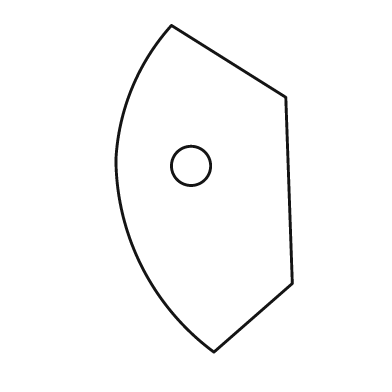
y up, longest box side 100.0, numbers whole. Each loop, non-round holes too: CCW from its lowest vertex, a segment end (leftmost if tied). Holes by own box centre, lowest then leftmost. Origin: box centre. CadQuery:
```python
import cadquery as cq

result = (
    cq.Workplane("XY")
    .moveTo(3.0, -50.0)
    .lineTo(27.0, -29.0)
    .lineTo(25.0, 28.0)
    .lineTo(-10.0, 50.0)
    .threePointArc((-22.0, 31.0), (-27.0, 9.0))
    .threePointArc((-19.0, -24.0), (3.0, -50.0))
    .close()
    .moveTo(-4.0, 7.0)
    .circle(6.0)
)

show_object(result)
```